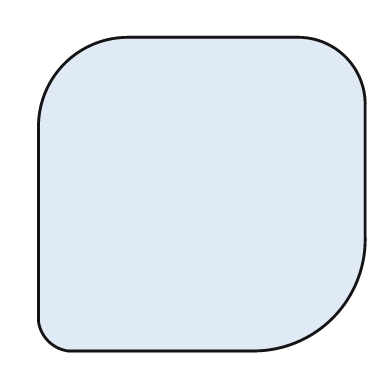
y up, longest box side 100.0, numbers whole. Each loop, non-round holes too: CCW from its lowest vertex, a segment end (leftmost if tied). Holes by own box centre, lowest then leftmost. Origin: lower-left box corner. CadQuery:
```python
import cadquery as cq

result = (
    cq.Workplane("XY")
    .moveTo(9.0, 0.0)
    .lineTo(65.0, 0.0)
    .threePointArc((90.0, 10.0), (100.0, 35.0))
    .lineTo(100.0, 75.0)
    .threePointArc((94.0, 90.0), (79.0, 96.0))
    .lineTo(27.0, 96.0)
    .threePointArc((8.0, 88.0), (0.0, 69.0))
    .lineTo(0.0, 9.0)
    .threePointArc((3.0, 3.0), (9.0, 0.0))
    .close()
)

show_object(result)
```